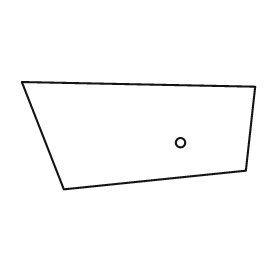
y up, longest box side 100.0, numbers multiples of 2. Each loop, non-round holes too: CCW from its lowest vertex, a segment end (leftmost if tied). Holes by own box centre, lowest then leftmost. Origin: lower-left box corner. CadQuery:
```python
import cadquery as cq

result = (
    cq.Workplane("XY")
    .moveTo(18.0, 0.0)
    .lineTo(96.0, 8.0)
    .lineTo(100.0, 44.0)
    .lineTo(0.0, 46.0)
    .close()
    .moveTo(68.0, 20.0)
    .circle(2.0)
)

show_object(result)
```